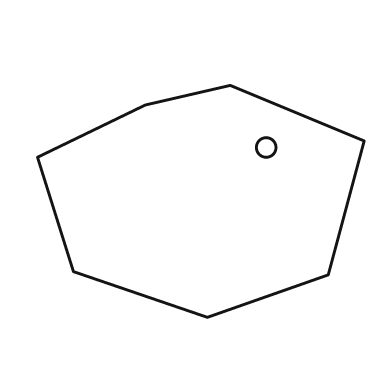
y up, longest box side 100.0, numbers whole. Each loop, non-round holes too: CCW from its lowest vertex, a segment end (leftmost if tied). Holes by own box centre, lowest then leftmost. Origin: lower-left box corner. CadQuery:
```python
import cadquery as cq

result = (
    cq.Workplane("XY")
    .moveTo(52.0, 0.0)
    .lineTo(89.0, 13.0)
    .lineTo(100.0, 54.0)
    .lineTo(59.0, 71.0)
    .lineTo(33.0, 65.0)
    .lineTo(0.0, 49.0)
    .lineTo(11.0, 14.0)
    .close()
    .moveTo(70.0, 52.0)
    .circle(3.0)
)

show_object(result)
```